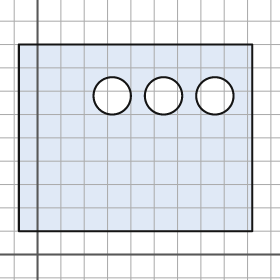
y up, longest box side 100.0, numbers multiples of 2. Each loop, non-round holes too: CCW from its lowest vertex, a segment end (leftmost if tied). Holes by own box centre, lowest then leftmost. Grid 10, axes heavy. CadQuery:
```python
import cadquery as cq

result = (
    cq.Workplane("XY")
    .moveTo(-8.0, 10.0)
    .lineTo(92.0, 10.0)
    .lineTo(92.0, 90.0)
    .lineTo(-8.0, 90.0)
    .close()
    .moveTo(32.0, 68.0)
    .circle(8.0)
    .moveTo(54.0, 68.0)
    .circle(8.0)
    .moveTo(76.0, 68.0)
    .circle(8.0)
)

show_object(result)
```